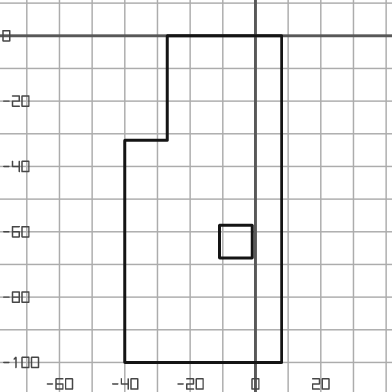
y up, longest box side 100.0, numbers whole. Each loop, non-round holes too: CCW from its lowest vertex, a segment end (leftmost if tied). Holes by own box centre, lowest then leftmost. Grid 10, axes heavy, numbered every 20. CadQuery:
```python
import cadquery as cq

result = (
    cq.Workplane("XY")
    .moveTo(-40.0, -100.0)
    .lineTo(8.0, -100.0)
    .lineTo(8.0, 0.0)
    .lineTo(-27.0, 0.0)
    .lineTo(-27.0, -32.0)
    .lineTo(-40.0, -32.0)
    .close()
    .moveTo(-11.0, -68.0)
    .lineTo(-1.0, -68.0)
    .lineTo(-1.0, -58.0)
    .lineTo(-11.0, -58.0)
    .close()
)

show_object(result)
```